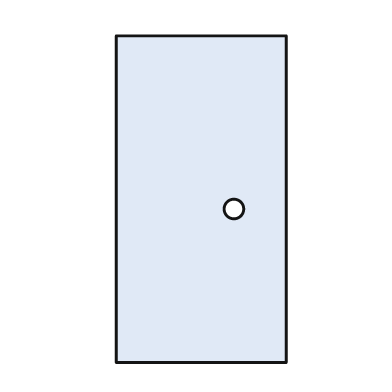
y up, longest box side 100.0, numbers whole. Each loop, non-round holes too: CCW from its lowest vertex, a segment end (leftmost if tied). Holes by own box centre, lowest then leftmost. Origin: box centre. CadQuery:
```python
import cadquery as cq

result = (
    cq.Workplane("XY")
    .moveTo(-26.0, -50.0)
    .lineTo(26.0, -50.0)
    .lineTo(26.0, 50.0)
    .lineTo(-26.0, 50.0)
    .close()
    .moveTo(10.0, -3.0)
    .circle(3.0)
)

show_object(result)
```